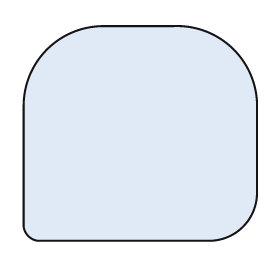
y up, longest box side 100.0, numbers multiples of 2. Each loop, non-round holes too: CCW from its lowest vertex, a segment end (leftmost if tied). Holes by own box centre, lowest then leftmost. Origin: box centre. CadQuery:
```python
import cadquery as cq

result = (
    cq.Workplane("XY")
    .moveTo(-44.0, -46.0)
    .lineTo(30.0, -46.0)
    .threePointArc((44.0, -40.0), (50.0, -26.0))
    .lineTo(50.0, 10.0)
    .threePointArc((40.0, 36.0), (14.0, 46.0))
    .lineTo(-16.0, 46.0)
    .threePointArc((-40.0, 36.0), (-50.0, 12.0))
    .lineTo(-50.0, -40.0)
    .threePointArc((-48.0, -44.0), (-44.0, -46.0))
    .close()
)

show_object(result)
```